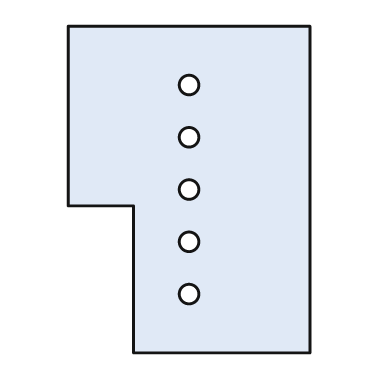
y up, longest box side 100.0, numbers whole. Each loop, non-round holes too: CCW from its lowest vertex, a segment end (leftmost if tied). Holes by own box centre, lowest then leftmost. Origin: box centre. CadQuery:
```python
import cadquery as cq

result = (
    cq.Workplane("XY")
    .moveTo(-17.0, -50.0)
    .lineTo(37.0, -50.0)
    .lineTo(37.0, 50.0)
    .lineTo(-37.0, 50.0)
    .lineTo(-37.0, -5.0)
    .lineTo(-17.0, -5.0)
    .close()
    .moveTo(0.0, -32.0)
    .circle(3.0)
    .moveTo(0.0, -16.0)
    .circle(3.0)
    .moveTo(0.0, 0.0)
    .circle(3.0)
    .moveTo(0.0, 16.0)
    .circle(3.0)
    .moveTo(0.0, 32.0)
    .circle(3.0)
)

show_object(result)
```